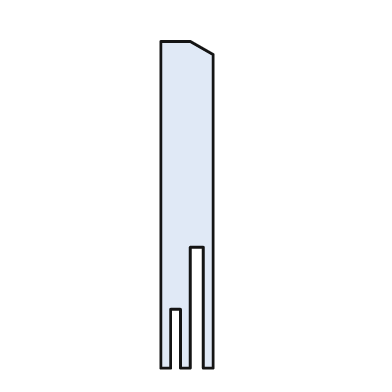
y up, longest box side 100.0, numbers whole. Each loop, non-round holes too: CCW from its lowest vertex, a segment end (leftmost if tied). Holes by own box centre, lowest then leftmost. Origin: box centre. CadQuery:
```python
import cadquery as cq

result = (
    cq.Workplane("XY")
    .moveTo(-8.0, -50.0)
    .lineTo(-5.0, -50.0)
    .lineTo(-5.0, -32.0)
    .lineTo(-2.0, -32.0)
    .lineTo(-2.0, -50.0)
    .lineTo(1.0, -50.0)
    .lineTo(1.0, -13.0)
    .lineTo(5.0, -13.0)
    .lineTo(5.0, -50.0)
    .lineTo(8.0, -50.0)
    .lineTo(8.0, 46.0)
    .lineTo(1.0, 50.0)
    .lineTo(-8.0, 50.0)
    .close()
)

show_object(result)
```